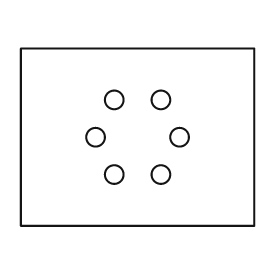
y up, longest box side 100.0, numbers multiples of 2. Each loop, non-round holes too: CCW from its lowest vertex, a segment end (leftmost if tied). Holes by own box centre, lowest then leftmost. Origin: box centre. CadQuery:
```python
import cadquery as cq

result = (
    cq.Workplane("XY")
    .moveTo(-50.0, -38.0)
    .lineTo(50.0, -38.0)
    .lineTo(50.0, 38.0)
    .lineTo(-50.0, 38.0)
    .close()
    .moveTo(-10.0, -16.0)
    .circle(4.0)
    .moveTo(10.0, -16.0)
    .circle(4.0)
    .moveTo(-18.0, 0.0)
    .circle(4.0)
    .moveTo(18.0, 0.0)
    .circle(4.0)
    .moveTo(-10.0, 16.0)
    .circle(4.0)
    .moveTo(10.0, 16.0)
    .circle(4.0)
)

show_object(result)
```